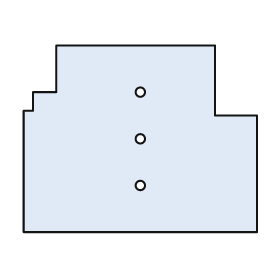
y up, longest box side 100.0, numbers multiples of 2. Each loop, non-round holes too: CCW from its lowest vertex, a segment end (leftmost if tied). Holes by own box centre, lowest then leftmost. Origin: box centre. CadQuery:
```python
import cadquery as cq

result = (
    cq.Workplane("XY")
    .moveTo(-50.0, -40.0)
    .lineTo(50.0, -40.0)
    .lineTo(50.0, 10.0)
    .lineTo(32.0, 10.0)
    .lineTo(32.0, 40.0)
    .lineTo(-36.0, 40.0)
    .lineTo(-36.0, 20.0)
    .lineTo(-46.0, 20.0)
    .lineTo(-46.0, 12.0)
    .lineTo(-50.0, 12.0)
    .close()
    .moveTo(0.0, -20.0)
    .circle(2.0)
    .moveTo(0.0, 0.0)
    .circle(2.0)
    .moveTo(0.0, 20.0)
    .circle(2.0)
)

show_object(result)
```